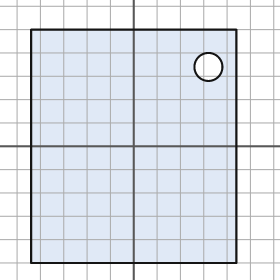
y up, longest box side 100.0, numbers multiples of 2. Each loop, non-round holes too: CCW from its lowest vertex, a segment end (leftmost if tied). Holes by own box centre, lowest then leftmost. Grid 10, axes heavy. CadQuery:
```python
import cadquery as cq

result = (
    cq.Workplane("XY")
    .moveTo(-44.0, -50.0)
    .lineTo(44.0, -50.0)
    .lineTo(44.0, 50.0)
    .lineTo(-44.0, 50.0)
    .close()
    .moveTo(32.0, 34.0)
    .circle(6.0)
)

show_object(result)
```